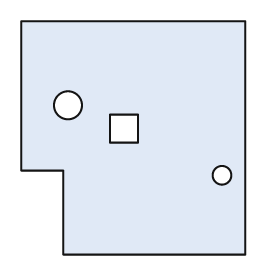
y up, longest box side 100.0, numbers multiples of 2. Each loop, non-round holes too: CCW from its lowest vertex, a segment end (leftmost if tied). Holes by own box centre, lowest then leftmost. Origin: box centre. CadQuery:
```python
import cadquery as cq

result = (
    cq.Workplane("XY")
    .moveTo(-30.0, -50.0)
    .lineTo(48.0, -50.0)
    .lineTo(48.0, 50.0)
    .lineTo(-48.0, 50.0)
    .lineTo(-48.0, -14.0)
    .lineTo(-30.0, -14.0)
    .close()
    .moveTo(38.0, -16.0)
    .circle(4.0)
    .moveTo(-10.0, -2.0)
    .lineTo(2.0, -2.0)
    .lineTo(2.0, 10.0)
    .lineTo(-10.0, 10.0)
    .close()
    .moveTo(-28.0, 14.0)
    .circle(6.0)
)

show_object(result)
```